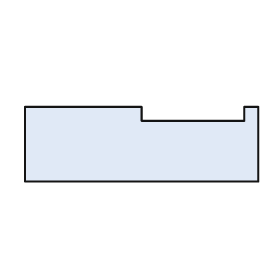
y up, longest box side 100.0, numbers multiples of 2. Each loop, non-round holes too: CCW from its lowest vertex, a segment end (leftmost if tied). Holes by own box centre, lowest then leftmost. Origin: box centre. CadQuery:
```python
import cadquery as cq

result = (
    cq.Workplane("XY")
    .moveTo(-50.0, -16.0)
    .lineTo(50.0, -16.0)
    .lineTo(50.0, 16.0)
    .lineTo(44.0, 16.0)
    .lineTo(44.0, 10.0)
    .lineTo(0.0, 10.0)
    .lineTo(0.0, 16.0)
    .lineTo(-50.0, 16.0)
    .close()
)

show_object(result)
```